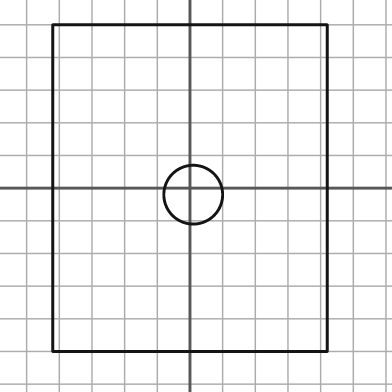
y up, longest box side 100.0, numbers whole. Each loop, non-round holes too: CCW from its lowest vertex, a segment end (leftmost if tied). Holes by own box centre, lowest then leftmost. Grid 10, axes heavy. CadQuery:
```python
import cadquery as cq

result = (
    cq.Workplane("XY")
    .moveTo(-42.0, -50.0)
    .lineTo(42.0, -50.0)
    .lineTo(42.0, 50.0)
    .lineTo(-42.0, 50.0)
    .close()
    .moveTo(1.0, -2.0)
    .circle(9.0)
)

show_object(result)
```